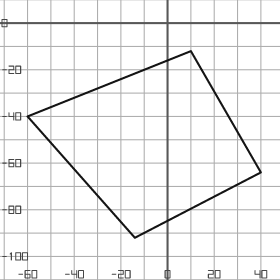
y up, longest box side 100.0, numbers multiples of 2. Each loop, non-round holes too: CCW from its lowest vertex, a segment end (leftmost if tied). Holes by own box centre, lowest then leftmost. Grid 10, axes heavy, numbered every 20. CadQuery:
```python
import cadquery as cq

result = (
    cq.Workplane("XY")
    .moveTo(-14.0, -92.0)
    .lineTo(40.0, -64.0)
    .lineTo(10.0, -12.0)
    .lineTo(-60.0, -40.0)
    .close()
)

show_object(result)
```